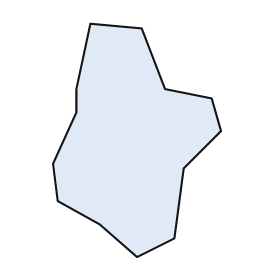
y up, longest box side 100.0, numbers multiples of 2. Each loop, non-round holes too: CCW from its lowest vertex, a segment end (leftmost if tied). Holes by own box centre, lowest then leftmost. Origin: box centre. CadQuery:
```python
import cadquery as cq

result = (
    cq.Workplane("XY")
    .moveTo(0.0, -50.0)
    .lineTo(16.0, -42.0)
    .lineTo(20.0, -12.0)
    .lineTo(36.0, 4.0)
    .lineTo(32.0, 18.0)
    .lineTo(12.0, 22.0)
    .lineTo(2.0, 48.0)
    .lineTo(-20.0, 50.0)
    .lineTo(-26.0, 22.0)
    .lineTo(-26.0, 12.0)
    .lineTo(-36.0, -10.0)
    .lineTo(-34.0, -26.0)
    .lineTo(-16.0, -36.0)
    .close()
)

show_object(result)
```